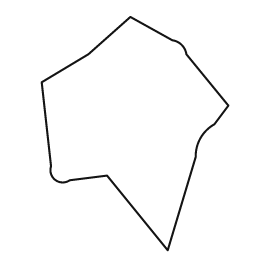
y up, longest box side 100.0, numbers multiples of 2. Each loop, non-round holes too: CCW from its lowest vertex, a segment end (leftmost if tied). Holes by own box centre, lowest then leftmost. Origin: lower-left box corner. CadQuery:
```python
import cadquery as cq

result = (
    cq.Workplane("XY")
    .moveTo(54.0, 0.0)
    .lineTo(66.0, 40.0)
    .threePointArc((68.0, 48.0), (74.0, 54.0))
    .lineTo(80.0, 62.0)
    .lineTo(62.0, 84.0)
    .threePointArc((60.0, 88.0), (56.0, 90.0))
    .lineTo(38.0, 100.0)
    .lineTo(20.0, 84.0)
    .lineTo(0.0, 72.0)
    .lineTo(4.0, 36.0)
    .threePointArc((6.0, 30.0), (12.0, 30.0))
    .lineTo(28.0, 32.0)
    .close()
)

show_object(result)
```